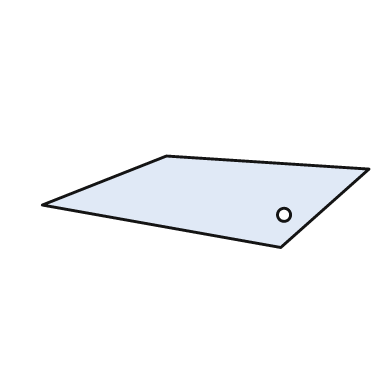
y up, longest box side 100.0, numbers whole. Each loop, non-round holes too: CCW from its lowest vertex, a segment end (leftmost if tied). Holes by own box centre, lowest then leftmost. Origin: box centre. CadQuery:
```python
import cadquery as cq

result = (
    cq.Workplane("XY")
    .moveTo(23.0, -14.0)
    .lineTo(50.0, 10.0)
    .lineTo(-12.0, 14.0)
    .lineTo(-50.0, -1.0)
    .close()
    .moveTo(24.0, -4.0)
    .circle(2.0)
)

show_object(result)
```